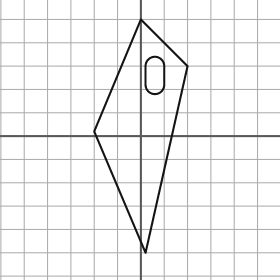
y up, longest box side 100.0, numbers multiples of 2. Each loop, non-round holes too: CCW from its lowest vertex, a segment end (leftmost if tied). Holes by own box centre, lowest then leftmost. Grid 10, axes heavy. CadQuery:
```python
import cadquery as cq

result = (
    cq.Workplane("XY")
    .moveTo(2.0, -50.0)
    .lineTo(20.0, 30.0)
    .lineTo(0.0, 50.0)
    .lineTo(-20.0, 2.0)
    .close()
    .moveTo(2.0, 22.0)
    .threePointArc((6.0, 18.0), (10.0, 22.0))
    .lineTo(10.0, 30.0)
    .threePointArc((6.0, 34.0), (2.0, 30.0))
    .close()
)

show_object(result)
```